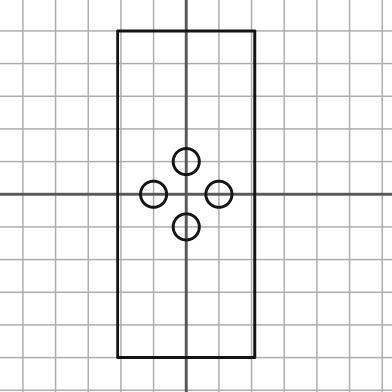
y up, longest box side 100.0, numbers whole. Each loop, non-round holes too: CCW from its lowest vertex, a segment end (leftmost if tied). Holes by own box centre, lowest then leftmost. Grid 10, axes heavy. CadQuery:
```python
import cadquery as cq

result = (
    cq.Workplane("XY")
    .moveTo(-21.0, -50.0)
    .lineTo(21.0, -50.0)
    .lineTo(21.0, 50.0)
    .lineTo(-21.0, 50.0)
    .close()
    .moveTo(0.0, -10.0)
    .circle(4.0)
    .moveTo(-10.0, 0.0)
    .circle(4.0)
    .moveTo(10.0, 0.0)
    .circle(4.0)
    .moveTo(0.0, 10.0)
    .circle(4.0)
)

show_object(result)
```